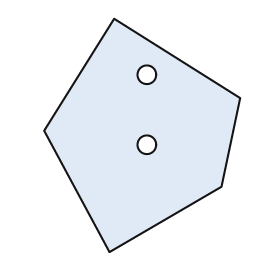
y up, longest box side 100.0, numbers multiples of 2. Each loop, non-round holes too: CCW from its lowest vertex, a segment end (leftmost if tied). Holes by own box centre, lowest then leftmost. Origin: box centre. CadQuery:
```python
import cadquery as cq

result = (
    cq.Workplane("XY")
    .moveTo(-14.0, -50.0)
    .lineTo(34.0, -22.0)
    .lineTo(42.0, 16.0)
    .lineTo(-12.0, 50.0)
    .lineTo(-42.0, 2.0)
    .close()
    .moveTo(2.0, -4.0)
    .circle(4.0)
    .moveTo(2.0, 26.0)
    .circle(4.0)
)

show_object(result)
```